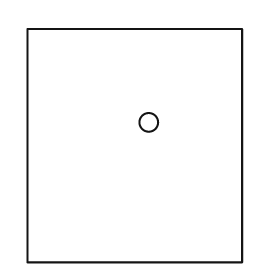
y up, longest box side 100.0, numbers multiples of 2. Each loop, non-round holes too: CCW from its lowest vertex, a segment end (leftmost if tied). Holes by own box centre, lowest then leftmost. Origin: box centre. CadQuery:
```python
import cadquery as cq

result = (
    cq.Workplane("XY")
    .moveTo(-46.0, -50.0)
    .lineTo(46.0, -50.0)
    .lineTo(46.0, 50.0)
    .lineTo(-46.0, 50.0)
    .close()
    .moveTo(6.0, 10.0)
    .circle(4.0)
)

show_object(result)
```